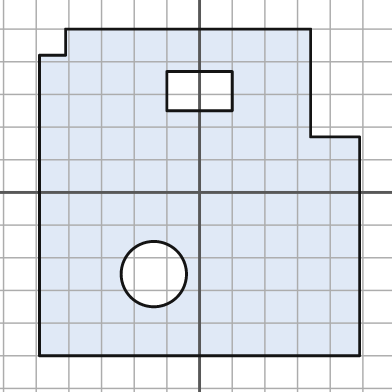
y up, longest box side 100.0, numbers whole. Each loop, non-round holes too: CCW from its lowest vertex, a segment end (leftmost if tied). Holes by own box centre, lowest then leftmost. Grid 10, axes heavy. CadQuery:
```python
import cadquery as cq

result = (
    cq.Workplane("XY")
    .moveTo(-49.0, -50.0)
    .lineTo(49.0, -50.0)
    .lineTo(49.0, 17.0)
    .lineTo(34.0, 17.0)
    .lineTo(34.0, 50.0)
    .lineTo(-41.0, 50.0)
    .lineTo(-41.0, 42.0)
    .lineTo(-49.0, 42.0)
    .close()
    .moveTo(-14.0, -25.0)
    .circle(10.0)
    .moveTo(-10.0, 25.0)
    .lineTo(10.0, 25.0)
    .lineTo(10.0, 37.0)
    .lineTo(-10.0, 37.0)
    .close()
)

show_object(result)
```